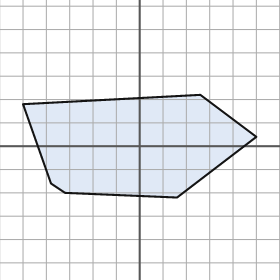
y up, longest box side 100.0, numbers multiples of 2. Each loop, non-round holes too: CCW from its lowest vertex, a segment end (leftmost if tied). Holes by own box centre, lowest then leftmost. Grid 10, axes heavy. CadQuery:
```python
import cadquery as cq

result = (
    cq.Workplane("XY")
    .moveTo(16.0, -22.0)
    .lineTo(50.0, 4.0)
    .lineTo(26.0, 22.0)
    .lineTo(-50.0, 18.0)
    .lineTo(-38.0, -16.0)
    .lineTo(-32.0, -20.0)
    .close()
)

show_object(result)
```